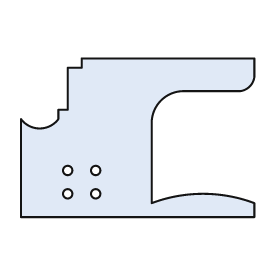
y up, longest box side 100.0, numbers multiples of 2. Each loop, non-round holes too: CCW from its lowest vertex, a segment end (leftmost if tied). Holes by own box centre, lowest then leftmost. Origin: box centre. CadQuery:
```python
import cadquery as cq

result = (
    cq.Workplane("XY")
    .moveTo(-50.0, -34.0)
    .lineTo(50.0, -34.0)
    .lineTo(50.0, -28.0)
    .threePointArc((28.0, -24.0), (6.0, -28.0))
    .lineTo(6.0, 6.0)
    .threePointArc((10.0, 16.0), (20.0, 20.0))
    .lineTo(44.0, 20.0)
    .threePointArc((48.0, 22.0), (50.0, 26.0))
    .lineTo(50.0, 34.0)
    .lineTo(-24.0, 34.0)
    .lineTo(-24.0, 30.0)
    .lineTo(-30.0, 30.0)
    .lineTo(-30.0, 12.0)
    .lineTo(-34.0, 12.0)
    .lineTo(-34.0, 8.0)
    .threePointArc((-42.0, 4.0), (-50.0, 8.0))
    .close()
    .moveTo(-30.0, -24.0)
    .circle(2.0)
    .moveTo(-18.0, -24.0)
    .circle(2.0)
    .moveTo(-30.0, -14.0)
    .circle(2.0)
    .moveTo(-18.0, -14.0)
    .circle(2.0)
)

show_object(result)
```